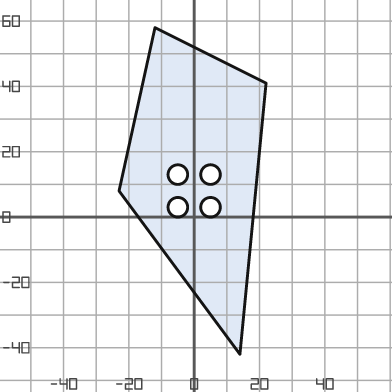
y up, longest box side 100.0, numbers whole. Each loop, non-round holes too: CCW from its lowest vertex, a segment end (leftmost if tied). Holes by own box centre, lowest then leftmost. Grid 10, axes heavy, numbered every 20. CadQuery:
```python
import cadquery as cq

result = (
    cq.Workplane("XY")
    .moveTo(14.0, -42.0)
    .lineTo(22.0, 41.0)
    .lineTo(-12.0, 58.0)
    .lineTo(-23.0, 8.0)
    .close()
    .moveTo(-5.0, 3.0)
    .circle(3.0)
    .moveTo(5.0, 3.0)
    .circle(3.0)
    .moveTo(-5.0, 13.0)
    .circle(3.0)
    .moveTo(5.0, 13.0)
    .circle(3.0)
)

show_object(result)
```